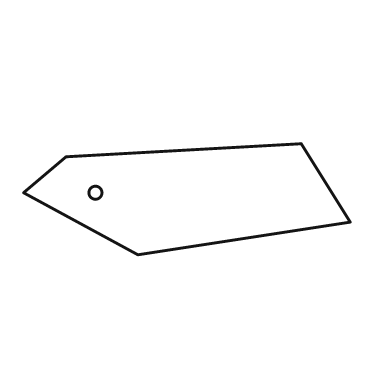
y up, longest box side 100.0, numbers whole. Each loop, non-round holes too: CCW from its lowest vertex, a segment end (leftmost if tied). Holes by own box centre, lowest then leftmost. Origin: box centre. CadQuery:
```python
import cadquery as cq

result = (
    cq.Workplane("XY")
    .moveTo(-15.0, -17.0)
    .lineTo(50.0, -7.0)
    .lineTo(35.0, 17.0)
    .lineTo(-37.0, 13.0)
    .lineTo(-50.0, 2.0)
    .close()
    .moveTo(-28.0, 2.0)
    .circle(2.0)
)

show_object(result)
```